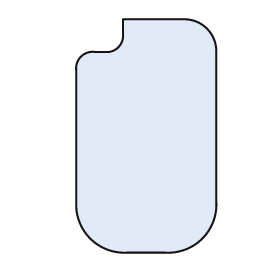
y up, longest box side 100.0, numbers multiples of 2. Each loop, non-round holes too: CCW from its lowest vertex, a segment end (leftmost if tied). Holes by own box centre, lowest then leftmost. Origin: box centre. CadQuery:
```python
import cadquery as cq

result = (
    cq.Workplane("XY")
    .moveTo(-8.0, -50.0)
    .lineTo(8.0, -50.0)
    .threePointArc((24.0, -44.0), (30.0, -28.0))
    .lineTo(30.0, 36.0)
    .threePointArc((26.0, 46.0), (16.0, 50.0))
    .lineTo(-10.0, 50.0)
    .lineTo(-10.0, 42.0)
    .threePointArc((-12.0, 38.0), (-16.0, 36.0))
    .lineTo(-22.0, 36.0)
    .threePointArc((-28.0, 34.0), (-30.0, 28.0))
    .lineTo(-30.0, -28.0)
    .threePointArc((-24.0, -44.0), (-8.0, -50.0))
    .close()
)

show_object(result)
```